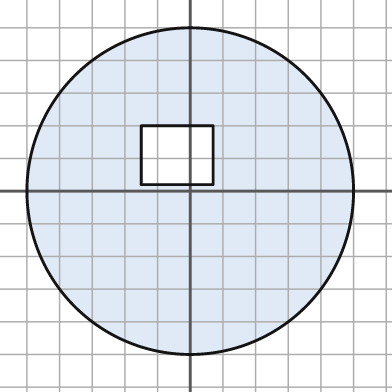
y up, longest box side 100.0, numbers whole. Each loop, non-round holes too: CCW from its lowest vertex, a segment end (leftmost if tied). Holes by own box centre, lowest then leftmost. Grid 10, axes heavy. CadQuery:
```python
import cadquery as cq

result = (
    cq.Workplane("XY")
    .moveTo(0.0, 0.0)
    .circle(50.0)
    .moveTo(-15.0, 2.0)
    .lineTo(7.0, 2.0)
    .lineTo(7.0, 20.0)
    .lineTo(-15.0, 20.0)
    .close()
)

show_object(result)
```